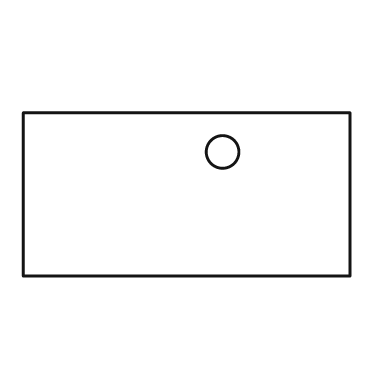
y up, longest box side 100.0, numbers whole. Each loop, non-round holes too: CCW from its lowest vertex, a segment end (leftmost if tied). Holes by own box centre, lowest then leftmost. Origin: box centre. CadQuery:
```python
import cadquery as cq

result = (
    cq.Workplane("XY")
    .moveTo(-50.0, -25.0)
    .lineTo(50.0, -25.0)
    .lineTo(50.0, 25.0)
    .lineTo(-50.0, 25.0)
    .close()
    .moveTo(11.0, 13.0)
    .circle(5.0)
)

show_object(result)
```